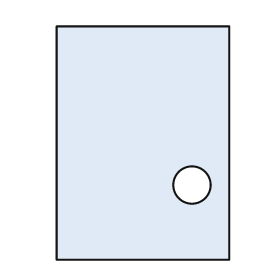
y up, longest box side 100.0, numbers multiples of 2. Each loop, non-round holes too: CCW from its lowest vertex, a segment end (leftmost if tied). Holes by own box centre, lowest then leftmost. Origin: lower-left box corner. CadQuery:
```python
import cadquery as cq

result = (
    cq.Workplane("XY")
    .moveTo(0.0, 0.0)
    .lineTo(74.0, 0.0)
    .lineTo(74.0, 100.0)
    .lineTo(0.0, 100.0)
    .close()
    .moveTo(58.0, 32.0)
    .circle(8.0)
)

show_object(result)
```